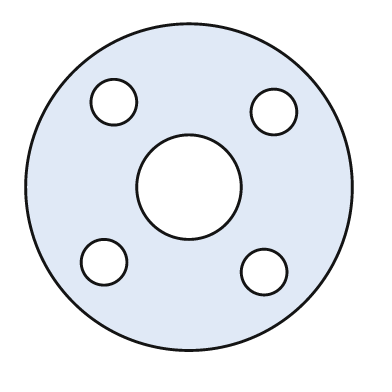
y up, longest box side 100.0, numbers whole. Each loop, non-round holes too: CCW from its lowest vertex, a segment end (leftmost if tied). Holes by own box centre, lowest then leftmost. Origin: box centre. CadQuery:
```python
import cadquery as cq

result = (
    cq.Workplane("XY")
    .moveTo(0.0, 0.0)
    .circle(50.0)
    .moveTo(23.0, -26.0)
    .circle(7.0)
    .moveTo(-26.0, -23.0)
    .circle(7.0)
    .moveTo(0.0, 0.0)
    .circle(16.0)
    .moveTo(26.0, 23.0)
    .circle(7.0)
    .moveTo(-23.0, 26.0)
    .circle(7.0)
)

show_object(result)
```